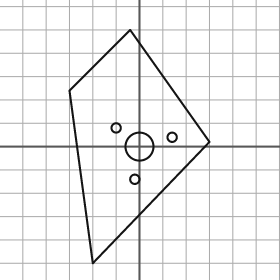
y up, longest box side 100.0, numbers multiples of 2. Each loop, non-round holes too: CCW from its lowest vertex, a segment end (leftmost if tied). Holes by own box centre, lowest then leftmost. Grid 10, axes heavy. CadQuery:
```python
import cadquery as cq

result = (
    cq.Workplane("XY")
    .moveTo(-20.0, -50.0)
    .lineTo(30.0, 2.0)
    .lineTo(-4.0, 50.0)
    .lineTo(-30.0, 24.0)
    .close()
    .moveTo(-2.0, -14.0)
    .circle(2.0)
    .moveTo(0.0, 0.0)
    .circle(6.0)
    .moveTo(14.0, 4.0)
    .circle(2.0)
    .moveTo(-10.0, 8.0)
    .circle(2.0)
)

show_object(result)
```